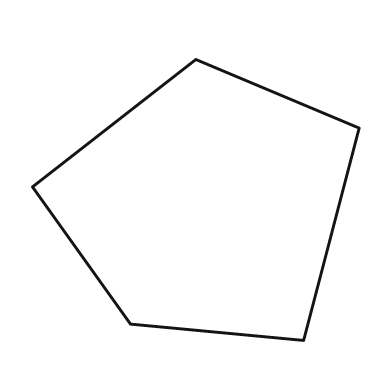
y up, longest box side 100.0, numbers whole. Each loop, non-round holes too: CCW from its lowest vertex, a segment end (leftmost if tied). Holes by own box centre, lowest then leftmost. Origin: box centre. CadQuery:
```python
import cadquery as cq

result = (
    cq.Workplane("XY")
    .moveTo(33.0, -43.0)
    .lineTo(50.0, 22.0)
    .lineTo(0.0, 43.0)
    .lineTo(-50.0, 4.0)
    .lineTo(-20.0, -38.0)
    .close()
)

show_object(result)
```